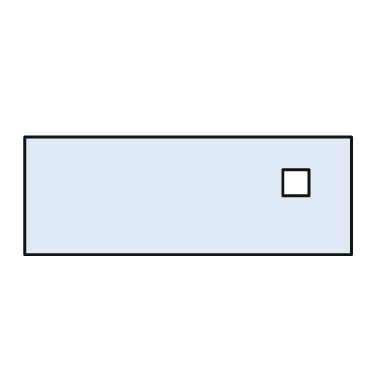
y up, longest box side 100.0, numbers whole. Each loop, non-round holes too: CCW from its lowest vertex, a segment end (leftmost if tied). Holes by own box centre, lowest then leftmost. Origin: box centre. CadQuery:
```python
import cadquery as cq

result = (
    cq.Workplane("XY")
    .moveTo(-50.0, -18.0)
    .lineTo(50.0, -18.0)
    .lineTo(50.0, 18.0)
    .lineTo(-50.0, 18.0)
    .close()
    .moveTo(29.0, 0.0)
    .lineTo(37.0, 0.0)
    .lineTo(37.0, 8.0)
    .lineTo(29.0, 8.0)
    .close()
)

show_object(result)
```